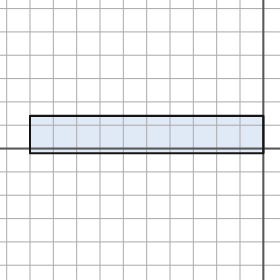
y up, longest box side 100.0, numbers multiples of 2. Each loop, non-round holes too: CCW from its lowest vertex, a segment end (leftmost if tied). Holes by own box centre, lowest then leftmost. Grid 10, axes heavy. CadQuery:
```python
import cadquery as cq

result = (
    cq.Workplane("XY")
    .moveTo(-100.0, -2.0)
    .lineTo(0.0, -2.0)
    .lineTo(0.0, 14.0)
    .lineTo(-100.0, 14.0)
    .close()
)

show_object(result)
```